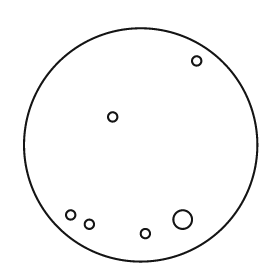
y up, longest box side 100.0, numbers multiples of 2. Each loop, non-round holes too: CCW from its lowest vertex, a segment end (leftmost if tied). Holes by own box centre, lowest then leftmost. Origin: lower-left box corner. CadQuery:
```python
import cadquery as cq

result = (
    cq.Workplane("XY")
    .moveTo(50.0, 50.0)
    .circle(50.0)
    .moveTo(52.0, 12.0)
    .circle(2.0)
    .moveTo(28.0, 16.0)
    .circle(2.0)
    .moveTo(68.0, 18.0)
    .circle(4.0)
    .moveTo(20.0, 20.0)
    .circle(2.0)
    .moveTo(38.0, 62.0)
    .circle(2.0)
    .moveTo(74.0, 86.0)
    .circle(2.0)
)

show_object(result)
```